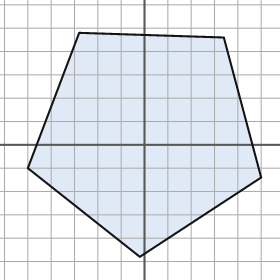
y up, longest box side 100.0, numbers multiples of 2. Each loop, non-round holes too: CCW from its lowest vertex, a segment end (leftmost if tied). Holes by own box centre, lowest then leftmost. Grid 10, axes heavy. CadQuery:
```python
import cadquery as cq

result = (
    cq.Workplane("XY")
    .moveTo(-2.0, -48.0)
    .lineTo(50.0, -14.0)
    .lineTo(34.0, 46.0)
    .lineTo(-28.0, 48.0)
    .lineTo(-50.0, -10.0)
    .close()
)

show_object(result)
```